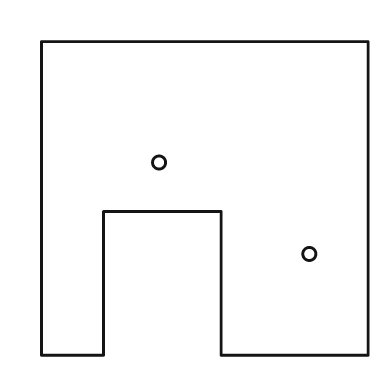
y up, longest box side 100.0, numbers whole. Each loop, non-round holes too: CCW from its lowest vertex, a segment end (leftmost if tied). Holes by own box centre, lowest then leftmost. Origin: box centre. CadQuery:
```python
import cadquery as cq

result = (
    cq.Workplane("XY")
    .moveTo(-50.0, -48.0)
    .lineTo(-31.0, -48.0)
    .lineTo(-31.0, -4.0)
    .lineTo(5.0, -4.0)
    .lineTo(5.0, -48.0)
    .lineTo(50.0, -48.0)
    .lineTo(50.0, 48.0)
    .lineTo(-50.0, 48.0)
    .close()
    .moveTo(32.0, -17.0)
    .circle(2.0)
    .moveTo(-14.0, 11.0)
    .circle(2.0)
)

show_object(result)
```